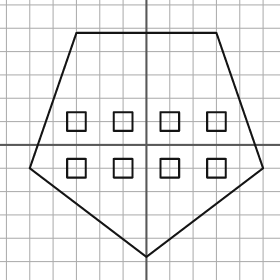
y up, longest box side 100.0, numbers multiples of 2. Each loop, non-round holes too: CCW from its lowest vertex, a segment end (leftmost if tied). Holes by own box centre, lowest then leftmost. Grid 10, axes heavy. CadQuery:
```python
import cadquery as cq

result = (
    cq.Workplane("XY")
    .moveTo(0.0, -48.0)
    .lineTo(50.0, -10.0)
    .lineTo(30.0, 48.0)
    .lineTo(-30.0, 48.0)
    .lineTo(-50.0, -10.0)
    .close()
    .moveTo(-34.0, -14.0)
    .lineTo(-26.0, -14.0)
    .lineTo(-26.0, -6.0)
    .lineTo(-34.0, -6.0)
    .close()
    .moveTo(-14.0, -14.0)
    .lineTo(-6.0, -14.0)
    .lineTo(-6.0, -6.0)
    .lineTo(-14.0, -6.0)
    .close()
    .moveTo(6.0, -14.0)
    .lineTo(14.0, -14.0)
    .lineTo(14.0, -6.0)
    .lineTo(6.0, -6.0)
    .close()
    .moveTo(26.0, -14.0)
    .lineTo(34.0, -14.0)
    .lineTo(34.0, -6.0)
    .lineTo(26.0, -6.0)
    .close()
    .moveTo(-34.0, 6.0)
    .lineTo(-26.0, 6.0)
    .lineTo(-26.0, 14.0)
    .lineTo(-34.0, 14.0)
    .close()
    .moveTo(-14.0, 6.0)
    .lineTo(-6.0, 6.0)
    .lineTo(-6.0, 14.0)
    .lineTo(-14.0, 14.0)
    .close()
    .moveTo(6.0, 6.0)
    .lineTo(14.0, 6.0)
    .lineTo(14.0, 14.0)
    .lineTo(6.0, 14.0)
    .close()
    .moveTo(26.0, 6.0)
    .lineTo(34.0, 6.0)
    .lineTo(34.0, 14.0)
    .lineTo(26.0, 14.0)
    .close()
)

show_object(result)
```